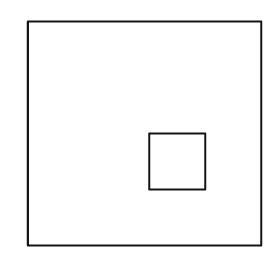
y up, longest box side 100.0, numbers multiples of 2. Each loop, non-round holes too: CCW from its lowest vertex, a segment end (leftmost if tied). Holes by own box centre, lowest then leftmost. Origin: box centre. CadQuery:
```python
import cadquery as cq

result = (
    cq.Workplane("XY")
    .moveTo(-50.0, -48.0)
    .lineTo(50.0, -48.0)
    .lineTo(50.0, 48.0)
    .lineTo(-50.0, 48.0)
    .close()
    .moveTo(2.0, -24.0)
    .lineTo(26.0, -24.0)
    .lineTo(26.0, 0.0)
    .lineTo(2.0, 0.0)
    .close()
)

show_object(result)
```